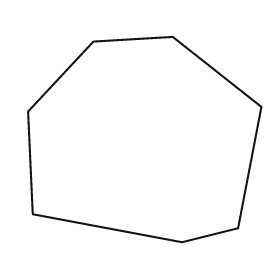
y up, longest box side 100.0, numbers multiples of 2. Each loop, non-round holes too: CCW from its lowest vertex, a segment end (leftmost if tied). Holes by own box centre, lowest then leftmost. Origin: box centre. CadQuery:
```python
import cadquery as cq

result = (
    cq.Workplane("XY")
    .moveTo(16.0, -44.0)
    .lineTo(40.0, -38.0)
    .lineTo(50.0, 14.0)
    .lineTo(12.0, 44.0)
    .lineTo(-22.0, 42.0)
    .lineTo(-50.0, 12.0)
    .lineTo(-48.0, -32.0)
    .close()
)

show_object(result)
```